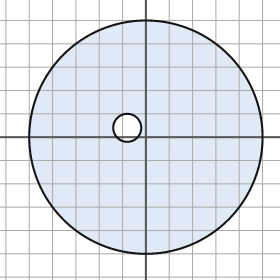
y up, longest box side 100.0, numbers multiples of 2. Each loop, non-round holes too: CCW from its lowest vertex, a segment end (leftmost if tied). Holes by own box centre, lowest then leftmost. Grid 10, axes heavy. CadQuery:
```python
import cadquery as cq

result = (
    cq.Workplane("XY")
    .moveTo(0.0, 0.0)
    .circle(50.0)
    .moveTo(-8.0, 4.0)
    .circle(6.0)
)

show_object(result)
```